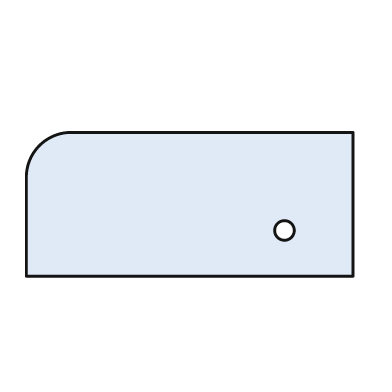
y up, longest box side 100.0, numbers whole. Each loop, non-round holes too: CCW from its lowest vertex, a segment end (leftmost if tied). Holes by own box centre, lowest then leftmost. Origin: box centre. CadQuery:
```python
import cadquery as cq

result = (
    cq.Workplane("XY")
    .moveTo(-50.0, -22.0)
    .lineTo(50.0, -22.0)
    .lineTo(50.0, 22.0)
    .lineTo(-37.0, 22.0)
    .threePointArc((-46.0, 18.0), (-50.0, 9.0))
    .close()
    .moveTo(29.0, -8.0)
    .circle(3.0)
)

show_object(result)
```